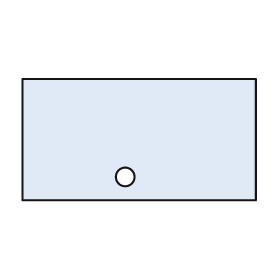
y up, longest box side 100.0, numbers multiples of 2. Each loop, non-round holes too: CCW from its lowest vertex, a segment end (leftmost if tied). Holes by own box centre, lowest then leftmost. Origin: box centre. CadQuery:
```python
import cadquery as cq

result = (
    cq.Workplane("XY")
    .moveTo(-50.0, -26.0)
    .lineTo(50.0, -26.0)
    .lineTo(50.0, 26.0)
    .lineTo(-50.0, 26.0)
    .close()
    .moveTo(-6.0, -16.0)
    .circle(4.0)
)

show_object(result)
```